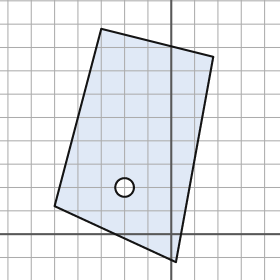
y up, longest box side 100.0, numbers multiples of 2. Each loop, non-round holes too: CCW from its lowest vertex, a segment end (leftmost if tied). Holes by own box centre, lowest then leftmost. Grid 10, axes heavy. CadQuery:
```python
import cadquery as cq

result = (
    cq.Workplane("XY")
    .moveTo(2.0, -12.0)
    .lineTo(18.0, 76.0)
    .lineTo(-30.0, 88.0)
    .lineTo(-50.0, 12.0)
    .close()
    .moveTo(-20.0, 20.0)
    .circle(4.0)
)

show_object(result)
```